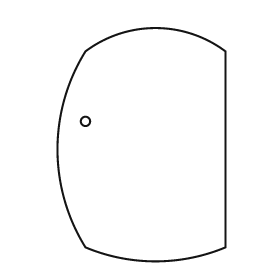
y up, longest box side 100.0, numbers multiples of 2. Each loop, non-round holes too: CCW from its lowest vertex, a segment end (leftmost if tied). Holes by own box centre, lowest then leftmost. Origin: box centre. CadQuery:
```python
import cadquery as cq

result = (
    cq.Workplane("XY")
    .moveTo(-24.0, -44.0)
    .threePointArc((6.0, -50.0), (36.0, -44.0))
    .lineTo(36.0, 40.0)
    .threePointArc((6.0, 50.0), (-24.0, 40.0))
    .threePointArc((-36.0, -2.0), (-24.0, -44.0))
    .close()
    .moveTo(-24.0, 10.0)
    .circle(2.0)
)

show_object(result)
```